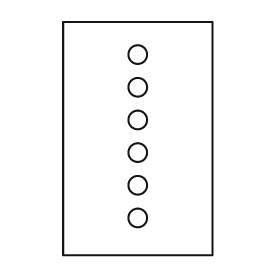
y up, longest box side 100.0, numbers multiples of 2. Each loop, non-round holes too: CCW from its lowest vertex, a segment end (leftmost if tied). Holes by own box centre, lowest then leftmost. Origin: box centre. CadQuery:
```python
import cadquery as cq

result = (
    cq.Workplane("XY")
    .moveTo(-32.0, -50.0)
    .lineTo(32.0, -50.0)
    .lineTo(32.0, 50.0)
    .lineTo(-32.0, 50.0)
    .close()
    .moveTo(0.0, -34.0)
    .circle(4.0)
    .moveTo(0.0, -20.0)
    .circle(4.0)
    .moveTo(0.0, -6.0)
    .circle(4.0)
    .moveTo(0.0, 8.0)
    .circle(4.0)
    .moveTo(0.0, 22.0)
    .circle(4.0)
    .moveTo(0.0, 36.0)
    .circle(4.0)
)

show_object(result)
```